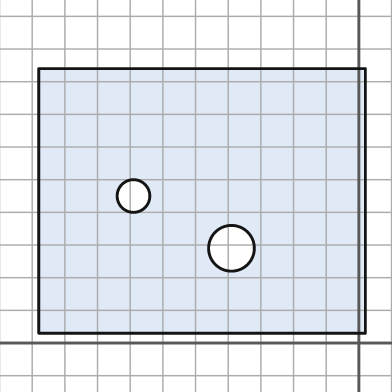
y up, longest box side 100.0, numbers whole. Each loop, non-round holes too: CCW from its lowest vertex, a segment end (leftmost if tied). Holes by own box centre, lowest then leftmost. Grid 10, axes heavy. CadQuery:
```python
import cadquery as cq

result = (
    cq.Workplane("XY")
    .moveTo(-98.0, 3.0)
    .lineTo(2.0, 3.0)
    .lineTo(2.0, 84.0)
    .lineTo(-98.0, 84.0)
    .close()
    .moveTo(-39.0, 29.0)
    .circle(7.0)
    .moveTo(-69.0, 45.0)
    .circle(5.0)
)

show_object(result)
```